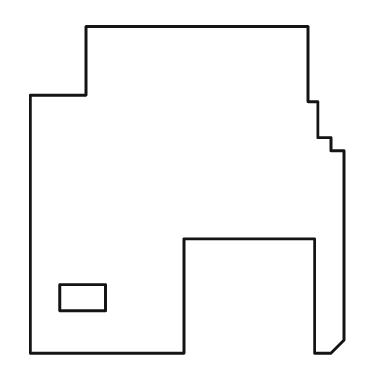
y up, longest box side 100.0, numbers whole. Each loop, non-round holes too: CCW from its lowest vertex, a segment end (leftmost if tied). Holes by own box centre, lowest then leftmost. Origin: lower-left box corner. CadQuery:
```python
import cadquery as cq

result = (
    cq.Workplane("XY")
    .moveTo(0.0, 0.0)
    .lineTo(47.0, 0.0)
    .lineTo(47.0, 35.0)
    .lineTo(87.0, 35.0)
    .lineTo(87.0, 0.0)
    .lineTo(92.0, 0.0)
    .lineTo(96.0, 4.0)
    .lineTo(96.0, 62.0)
    .lineTo(92.0, 62.0)
    .lineTo(92.0, 66.0)
    .lineTo(88.0, 66.0)
    .lineTo(88.0, 77.0)
    .lineTo(85.0, 77.0)
    .lineTo(85.0, 100.0)
    .lineTo(17.0, 100.0)
    .lineTo(17.0, 79.0)
    .lineTo(0.0, 79.0)
    .close()
    .moveTo(9.0, 13.0)
    .lineTo(23.0, 13.0)
    .lineTo(23.0, 21.0)
    .lineTo(9.0, 21.0)
    .close()
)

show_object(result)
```